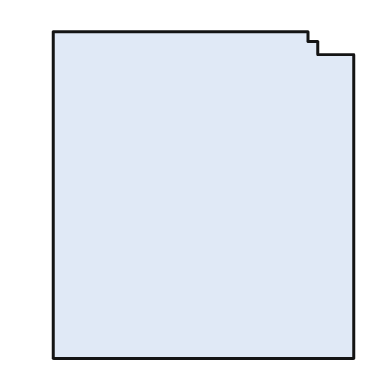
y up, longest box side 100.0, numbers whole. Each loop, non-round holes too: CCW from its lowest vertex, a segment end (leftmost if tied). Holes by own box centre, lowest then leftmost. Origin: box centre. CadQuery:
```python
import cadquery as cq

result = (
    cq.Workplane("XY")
    .moveTo(-46.0, -50.0)
    .lineTo(46.0, -50.0)
    .lineTo(46.0, 43.0)
    .lineTo(35.0, 43.0)
    .lineTo(35.0, 47.0)
    .lineTo(32.0, 47.0)
    .lineTo(32.0, 50.0)
    .lineTo(-46.0, 50.0)
    .close()
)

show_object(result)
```